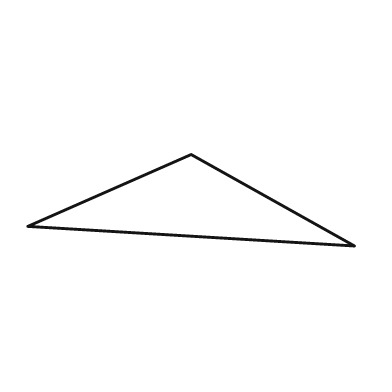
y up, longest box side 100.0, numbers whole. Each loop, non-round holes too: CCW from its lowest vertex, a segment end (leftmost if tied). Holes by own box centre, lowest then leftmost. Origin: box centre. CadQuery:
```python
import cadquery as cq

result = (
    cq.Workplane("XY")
    .moveTo(50.0, -14.0)
    .lineTo(0.0, 14.0)
    .lineTo(-50.0, -8.0)
    .close()
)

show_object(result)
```